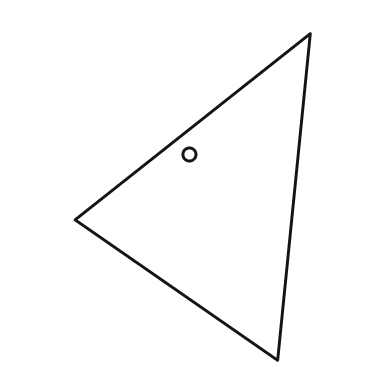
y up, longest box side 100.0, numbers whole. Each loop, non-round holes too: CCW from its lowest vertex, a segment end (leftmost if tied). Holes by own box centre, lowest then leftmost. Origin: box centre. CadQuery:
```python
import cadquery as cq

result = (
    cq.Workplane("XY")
    .moveTo(26.0, -50.0)
    .lineTo(36.0, 50.0)
    .lineTo(-36.0, -7.0)
    .close()
    .moveTo(-1.0, 13.0)
    .circle(2.0)
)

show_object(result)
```